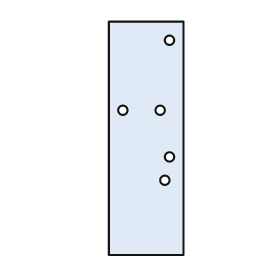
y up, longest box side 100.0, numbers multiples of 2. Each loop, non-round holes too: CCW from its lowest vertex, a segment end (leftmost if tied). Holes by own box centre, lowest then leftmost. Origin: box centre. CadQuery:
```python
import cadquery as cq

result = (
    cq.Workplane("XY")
    .moveTo(-16.0, -50.0)
    .lineTo(16.0, -50.0)
    .lineTo(16.0, 50.0)
    .lineTo(-16.0, 50.0)
    .close()
    .moveTo(8.0, -18.0)
    .circle(2.0)
    .moveTo(10.0, -8.0)
    .circle(2.0)
    .moveTo(-10.0, 12.0)
    .circle(2.0)
    .moveTo(6.0, 12.0)
    .circle(2.0)
    .moveTo(10.0, 42.0)
    .circle(2.0)
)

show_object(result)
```